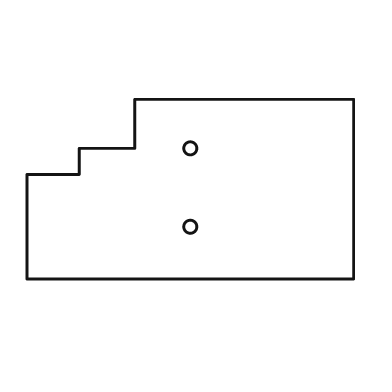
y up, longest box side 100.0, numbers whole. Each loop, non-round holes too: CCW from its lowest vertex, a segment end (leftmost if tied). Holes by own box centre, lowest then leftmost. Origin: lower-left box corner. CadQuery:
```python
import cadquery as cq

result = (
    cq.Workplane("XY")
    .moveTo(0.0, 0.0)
    .lineTo(100.0, 0.0)
    .lineTo(100.0, 55.0)
    .lineTo(33.0, 55.0)
    .lineTo(33.0, 40.0)
    .lineTo(16.0, 40.0)
    .lineTo(16.0, 32.0)
    .lineTo(0.0, 32.0)
    .close()
    .moveTo(50.0, 16.0)
    .circle(2.0)
    .moveTo(50.0, 40.0)
    .circle(2.0)
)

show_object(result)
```